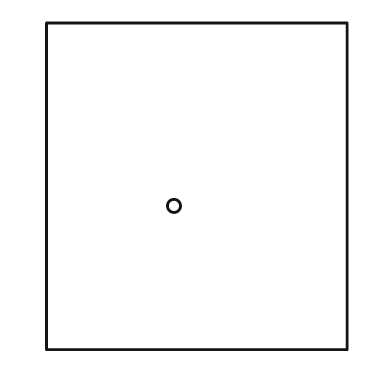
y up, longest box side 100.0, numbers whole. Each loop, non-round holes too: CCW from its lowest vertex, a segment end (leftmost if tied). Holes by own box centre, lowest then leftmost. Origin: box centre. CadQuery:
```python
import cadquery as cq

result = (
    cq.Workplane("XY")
    .moveTo(-46.0, -50.0)
    .lineTo(46.0, -50.0)
    .lineTo(46.0, 50.0)
    .lineTo(-46.0, 50.0)
    .close()
    .moveTo(-7.0, -6.0)
    .circle(2.0)
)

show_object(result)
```